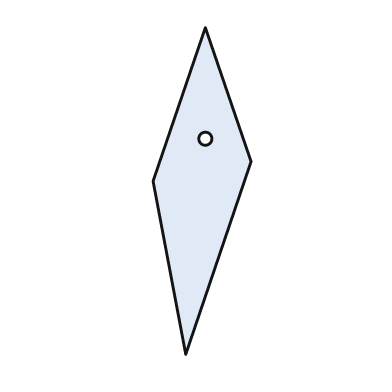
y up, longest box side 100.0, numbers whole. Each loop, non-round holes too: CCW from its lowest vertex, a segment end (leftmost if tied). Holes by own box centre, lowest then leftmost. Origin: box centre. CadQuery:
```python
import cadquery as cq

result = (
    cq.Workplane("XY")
    .moveTo(-5.0, -50.0)
    .lineTo(15.0, 9.0)
    .lineTo(1.0, 50.0)
    .lineTo(-15.0, 3.0)
    .close()
    .moveTo(1.0, 16.0)
    .circle(2.0)
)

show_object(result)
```